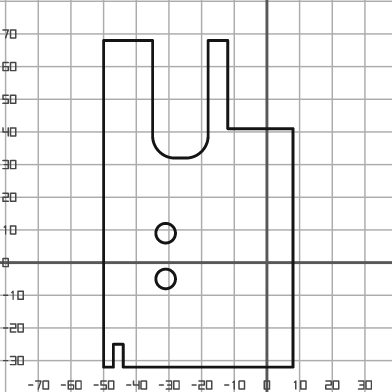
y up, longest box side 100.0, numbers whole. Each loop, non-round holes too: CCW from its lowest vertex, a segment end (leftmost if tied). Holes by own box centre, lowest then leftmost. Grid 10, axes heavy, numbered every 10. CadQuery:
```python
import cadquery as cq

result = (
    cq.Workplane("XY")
    .moveTo(-50.0, -32.0)
    .lineTo(-47.0, -32.0)
    .lineTo(-47.0, -25.0)
    .lineTo(-44.0, -25.0)
    .lineTo(-44.0, -32.0)
    .lineTo(8.0, -32.0)
    .lineTo(8.0, 41.0)
    .lineTo(-12.0, 41.0)
    .lineTo(-12.0, 68.0)
    .lineTo(-18.0, 68.0)
    .lineTo(-18.0, 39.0)
    .threePointArc((-20.0, 34.0), (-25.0, 32.0))
    .lineTo(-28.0, 32.0)
    .threePointArc((-33.0, 34.0), (-35.0, 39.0))
    .lineTo(-35.0, 68.0)
    .lineTo(-50.0, 68.0)
    .close()
    .moveTo(-31.0, -5.0)
    .circle(3.0)
    .moveTo(-31.0, 9.0)
    .circle(3.0)
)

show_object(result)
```